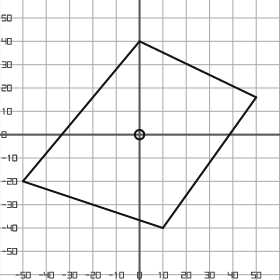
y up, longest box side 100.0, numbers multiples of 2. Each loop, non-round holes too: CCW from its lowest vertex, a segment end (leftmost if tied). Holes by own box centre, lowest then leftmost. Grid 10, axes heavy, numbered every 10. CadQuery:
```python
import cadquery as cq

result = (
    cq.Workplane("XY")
    .moveTo(10.0, -40.0)
    .lineTo(50.0, 16.0)
    .lineTo(0.0, 40.0)
    .lineTo(-50.0, -20.0)
    .close()
    .moveTo(0.0, 0.0)
    .circle(2.0)
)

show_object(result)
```